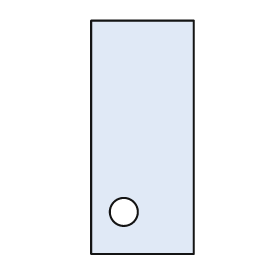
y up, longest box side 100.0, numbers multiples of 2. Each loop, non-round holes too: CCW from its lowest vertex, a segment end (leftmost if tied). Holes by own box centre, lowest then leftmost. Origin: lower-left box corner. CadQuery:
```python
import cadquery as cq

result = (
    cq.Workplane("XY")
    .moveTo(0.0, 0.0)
    .lineTo(44.0, 0.0)
    .lineTo(44.0, 100.0)
    .lineTo(0.0, 100.0)
    .close()
    .moveTo(14.0, 18.0)
    .circle(6.0)
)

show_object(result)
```